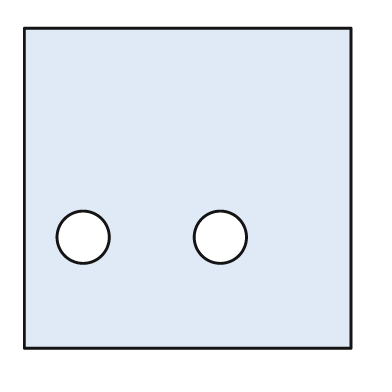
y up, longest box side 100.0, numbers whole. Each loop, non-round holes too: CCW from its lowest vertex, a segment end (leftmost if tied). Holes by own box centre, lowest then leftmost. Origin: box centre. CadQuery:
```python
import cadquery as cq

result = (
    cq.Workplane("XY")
    .moveTo(-50.0, -49.0)
    .lineTo(50.0, -49.0)
    .lineTo(50.0, 49.0)
    .lineTo(-50.0, 49.0)
    .close()
    .moveTo(-32.0, -15.0)
    .circle(8.0)
    .moveTo(10.0, -15.0)
    .circle(8.0)
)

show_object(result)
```